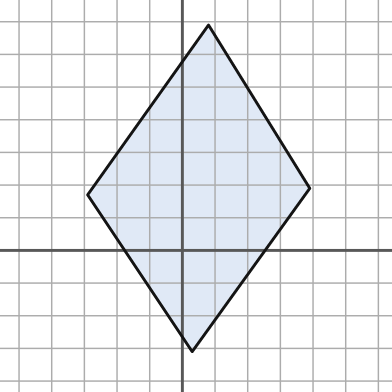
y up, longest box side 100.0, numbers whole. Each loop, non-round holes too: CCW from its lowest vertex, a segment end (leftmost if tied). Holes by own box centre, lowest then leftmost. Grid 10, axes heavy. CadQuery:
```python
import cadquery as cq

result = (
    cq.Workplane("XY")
    .moveTo(3.0, -31.0)
    .lineTo(39.0, 19.0)
    .lineTo(8.0, 69.0)
    .lineTo(-29.0, 17.0)
    .close()
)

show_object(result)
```